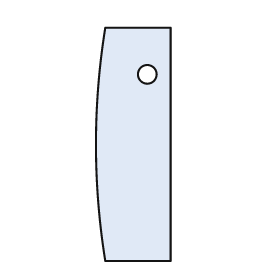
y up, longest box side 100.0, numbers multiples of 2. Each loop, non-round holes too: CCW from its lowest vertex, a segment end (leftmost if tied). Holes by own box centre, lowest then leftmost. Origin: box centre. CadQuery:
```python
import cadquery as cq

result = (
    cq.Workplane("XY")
    .moveTo(-12.0, -50.0)
    .lineTo(16.0, -50.0)
    .lineTo(16.0, 50.0)
    .lineTo(-12.0, 50.0)
    .threePointArc((-16.0, 0.0), (-12.0, -50.0))
    .close()
    .moveTo(6.0, 30.0)
    .circle(4.0)
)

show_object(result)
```